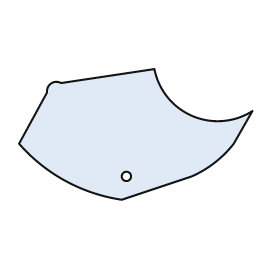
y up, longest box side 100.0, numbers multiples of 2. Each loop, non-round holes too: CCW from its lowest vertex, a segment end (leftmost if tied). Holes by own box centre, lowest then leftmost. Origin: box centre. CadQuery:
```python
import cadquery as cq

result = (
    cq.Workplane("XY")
    .moveTo(-6.0, -28.0)
    .lineTo(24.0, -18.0)
    .threePointArc((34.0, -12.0), (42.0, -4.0))
    .lineTo(50.0, 10.0)
    .threePointArc((24.0, 8.0), (8.0, 28.0))
    .lineTo(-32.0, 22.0)
    .threePointArc((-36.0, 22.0), (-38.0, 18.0))
    .lineTo(-50.0, -4.0)
    .threePointArc((-30.0, -20.0), (-6.0, -28.0))
    .close()
    .moveTo(-4.0, -18.0)
    .circle(2.0)
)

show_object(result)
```